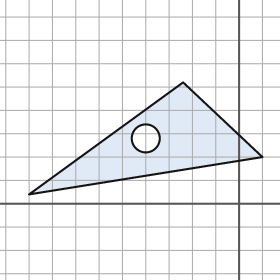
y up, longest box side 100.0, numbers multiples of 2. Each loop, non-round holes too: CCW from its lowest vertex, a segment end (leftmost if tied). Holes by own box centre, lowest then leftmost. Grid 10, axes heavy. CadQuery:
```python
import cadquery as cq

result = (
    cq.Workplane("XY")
    .moveTo(-90.0, 4.0)
    .lineTo(10.0, 20.0)
    .lineTo(-24.0, 52.0)
    .close()
    .moveTo(-40.0, 28.0)
    .circle(6.0)
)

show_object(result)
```